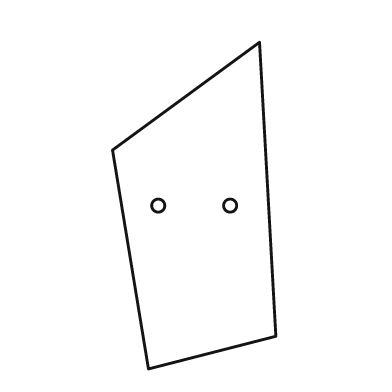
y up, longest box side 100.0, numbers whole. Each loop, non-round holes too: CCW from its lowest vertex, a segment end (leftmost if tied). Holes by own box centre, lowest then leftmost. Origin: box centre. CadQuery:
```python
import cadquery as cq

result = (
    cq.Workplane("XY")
    .moveTo(-14.0, -50.0)
    .lineTo(25.0, -40.0)
    .lineTo(20.0, 50.0)
    .lineTo(-25.0, 17.0)
    .close()
    .moveTo(-11.0, 0.0)
    .circle(2.0)
    .moveTo(11.0, 0.0)
    .circle(2.0)
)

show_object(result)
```